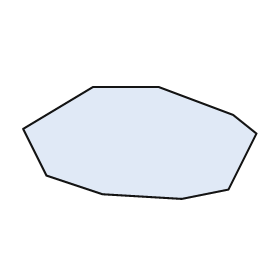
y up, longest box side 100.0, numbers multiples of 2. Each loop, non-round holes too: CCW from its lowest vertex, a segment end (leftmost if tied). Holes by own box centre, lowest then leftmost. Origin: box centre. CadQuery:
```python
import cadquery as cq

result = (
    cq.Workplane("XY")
    .moveTo(18.0, -24.0)
    .lineTo(38.0, -20.0)
    .lineTo(50.0, 4.0)
    .lineTo(40.0, 12.0)
    .lineTo(8.0, 24.0)
    .lineTo(-20.0, 24.0)
    .lineTo(-50.0, 6.0)
    .lineTo(-40.0, -14.0)
    .lineTo(-16.0, -22.0)
    .close()
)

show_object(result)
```